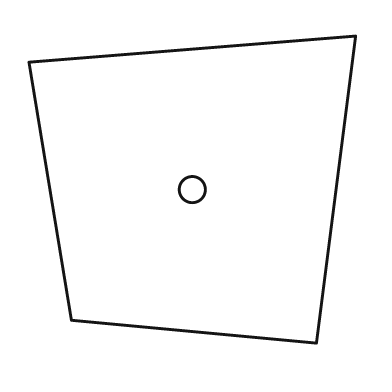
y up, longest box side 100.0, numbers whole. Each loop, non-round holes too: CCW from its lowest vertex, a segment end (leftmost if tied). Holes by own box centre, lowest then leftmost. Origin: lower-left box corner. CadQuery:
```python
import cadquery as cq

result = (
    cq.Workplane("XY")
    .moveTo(88.0, 0.0)
    .lineTo(100.0, 94.0)
    .lineTo(0.0, 86.0)
    .lineTo(13.0, 7.0)
    .close()
    .moveTo(50.0, 47.0)
    .circle(4.0)
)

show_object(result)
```